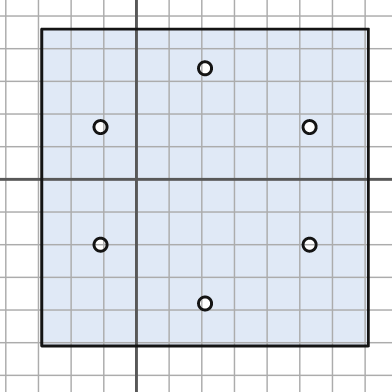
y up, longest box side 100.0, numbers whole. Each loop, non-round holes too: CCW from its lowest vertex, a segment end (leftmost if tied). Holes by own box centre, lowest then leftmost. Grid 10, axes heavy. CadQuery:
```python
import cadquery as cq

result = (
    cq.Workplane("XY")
    .moveTo(-29.0, -51.0)
    .lineTo(71.0, -51.0)
    .lineTo(71.0, 46.0)
    .lineTo(-29.0, 46.0)
    .close()
    .moveTo(21.0, -38.0)
    .circle(2.0)
    .moveTo(-11.0, -20.0)
    .circle(2.0)
    .moveTo(53.0, -20.0)
    .circle(2.0)
    .moveTo(-11.0, 16.0)
    .circle(2.0)
    .moveTo(53.0, 16.0)
    .circle(2.0)
    .moveTo(21.0, 34.0)
    .circle(2.0)
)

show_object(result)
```